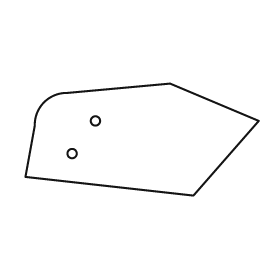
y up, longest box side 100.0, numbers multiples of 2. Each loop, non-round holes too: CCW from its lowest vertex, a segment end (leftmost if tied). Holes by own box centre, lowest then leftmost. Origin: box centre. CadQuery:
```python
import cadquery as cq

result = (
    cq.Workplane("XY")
    .moveTo(22.0, -24.0)
    .lineTo(50.0, 8.0)
    .lineTo(12.0, 24.0)
    .lineTo(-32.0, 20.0)
    .threePointArc((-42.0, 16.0), (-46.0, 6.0))
    .lineTo(-50.0, -16.0)
    .close()
    .moveTo(-30.0, -6.0)
    .circle(2.0)
    .moveTo(-20.0, 8.0)
    .circle(2.0)
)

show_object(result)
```